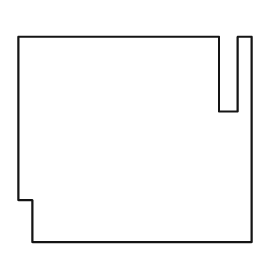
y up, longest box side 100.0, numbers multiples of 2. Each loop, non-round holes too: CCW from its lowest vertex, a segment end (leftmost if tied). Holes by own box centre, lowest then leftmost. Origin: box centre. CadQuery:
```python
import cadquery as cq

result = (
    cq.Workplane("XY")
    .moveTo(-44.0, -44.0)
    .lineTo(50.0, -44.0)
    .lineTo(50.0, 44.0)
    .lineTo(44.0, 44.0)
    .lineTo(44.0, 12.0)
    .lineTo(36.0, 12.0)
    .lineTo(36.0, 44.0)
    .lineTo(-50.0, 44.0)
    .lineTo(-50.0, -26.0)
    .lineTo(-44.0, -26.0)
    .close()
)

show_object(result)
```